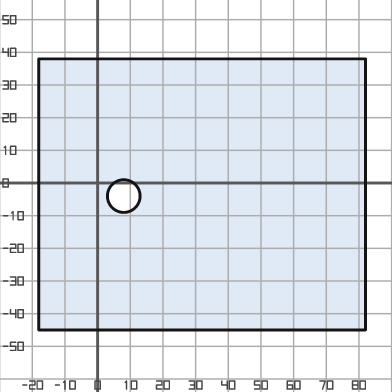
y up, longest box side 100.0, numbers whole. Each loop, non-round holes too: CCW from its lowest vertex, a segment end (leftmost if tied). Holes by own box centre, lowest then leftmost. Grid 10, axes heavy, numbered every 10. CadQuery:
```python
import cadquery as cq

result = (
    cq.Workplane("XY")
    .moveTo(-18.0, -45.0)
    .lineTo(82.0, -45.0)
    .lineTo(82.0, 38.0)
    .lineTo(-18.0, 38.0)
    .close()
    .moveTo(8.0, -4.0)
    .circle(5.0)
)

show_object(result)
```